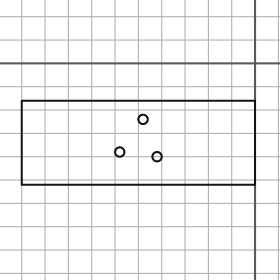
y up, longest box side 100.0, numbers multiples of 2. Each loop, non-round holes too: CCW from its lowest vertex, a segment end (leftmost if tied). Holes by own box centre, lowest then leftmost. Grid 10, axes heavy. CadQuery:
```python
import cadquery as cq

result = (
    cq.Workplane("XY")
    .moveTo(-100.0, -52.0)
    .lineTo(0.0, -52.0)
    .lineTo(0.0, -16.0)
    .lineTo(-100.0, -16.0)
    .close()
    .moveTo(-42.0, -40.0)
    .circle(2.0)
    .moveTo(-58.0, -38.0)
    .circle(2.0)
    .moveTo(-48.0, -24.0)
    .circle(2.0)
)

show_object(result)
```